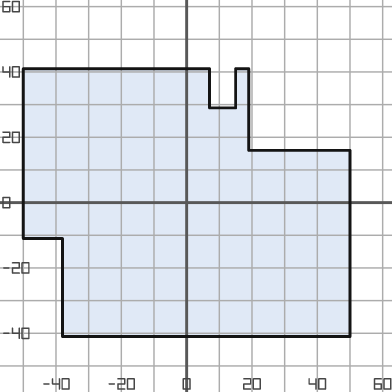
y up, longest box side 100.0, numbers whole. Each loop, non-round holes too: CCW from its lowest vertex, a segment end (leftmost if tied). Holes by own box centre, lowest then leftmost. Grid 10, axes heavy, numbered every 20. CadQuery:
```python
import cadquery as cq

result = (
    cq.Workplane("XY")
    .moveTo(-38.0, -41.0)
    .lineTo(50.0, -41.0)
    .lineTo(50.0, 16.0)
    .lineTo(19.0, 16.0)
    .lineTo(19.0, 41.0)
    .lineTo(15.0, 41.0)
    .lineTo(15.0, 29.0)
    .lineTo(7.0, 29.0)
    .lineTo(7.0, 41.0)
    .lineTo(-50.0, 41.0)
    .lineTo(-50.0, -11.0)
    .lineTo(-38.0, -11.0)
    .close()
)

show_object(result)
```